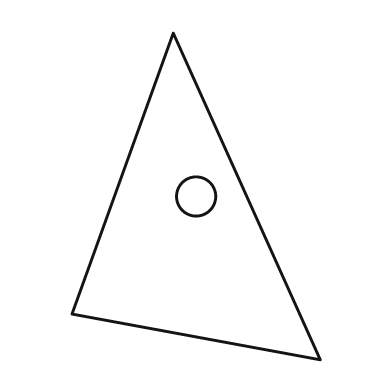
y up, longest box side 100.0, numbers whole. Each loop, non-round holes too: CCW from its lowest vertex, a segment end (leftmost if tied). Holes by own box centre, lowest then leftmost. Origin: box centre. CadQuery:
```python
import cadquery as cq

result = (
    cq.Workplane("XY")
    .moveTo(38.0, -50.0)
    .lineTo(-7.0, 50.0)
    .lineTo(-38.0, -36.0)
    .close()
    .moveTo(0.0, 0.0)
    .circle(6.0)
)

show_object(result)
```